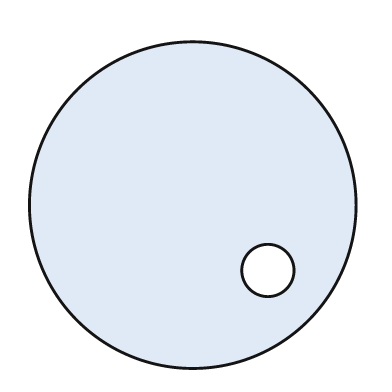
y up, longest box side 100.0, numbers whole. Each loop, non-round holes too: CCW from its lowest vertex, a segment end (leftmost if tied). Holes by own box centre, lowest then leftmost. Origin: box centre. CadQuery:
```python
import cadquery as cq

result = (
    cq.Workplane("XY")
    .moveTo(0.0, 0.0)
    .circle(50.0)
    .moveTo(23.0, -20.0)
    .circle(8.0)
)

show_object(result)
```